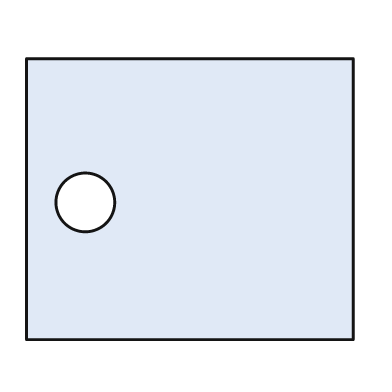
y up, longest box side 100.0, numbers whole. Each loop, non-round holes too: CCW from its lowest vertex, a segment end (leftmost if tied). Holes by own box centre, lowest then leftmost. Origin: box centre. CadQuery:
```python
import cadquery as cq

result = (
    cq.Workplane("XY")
    .moveTo(-50.0, -43.0)
    .lineTo(50.0, -43.0)
    .lineTo(50.0, 43.0)
    .lineTo(-50.0, 43.0)
    .close()
    .moveTo(-32.0, -1.0)
    .circle(9.0)
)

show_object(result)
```